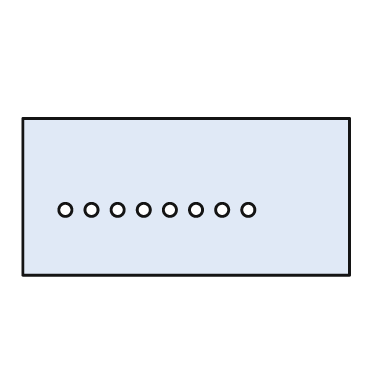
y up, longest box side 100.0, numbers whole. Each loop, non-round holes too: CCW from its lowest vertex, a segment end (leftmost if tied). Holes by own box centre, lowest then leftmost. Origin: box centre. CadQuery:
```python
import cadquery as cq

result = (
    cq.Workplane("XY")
    .moveTo(-50.0, -24.0)
    .lineTo(50.0, -24.0)
    .lineTo(50.0, 24.0)
    .lineTo(-50.0, 24.0)
    .close()
    .moveTo(-37.0, -4.0)
    .circle(2.0)
    .moveTo(-29.0, -4.0)
    .circle(2.0)
    .moveTo(-21.0, -4.0)
    .circle(2.0)
    .moveTo(-13.0, -4.0)
    .circle(2.0)
    .moveTo(-5.0, -4.0)
    .circle(2.0)
    .moveTo(3.0, -4.0)
    .circle(2.0)
    .moveTo(11.0, -4.0)
    .circle(2.0)
    .moveTo(19.0, -4.0)
    .circle(2.0)
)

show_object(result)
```